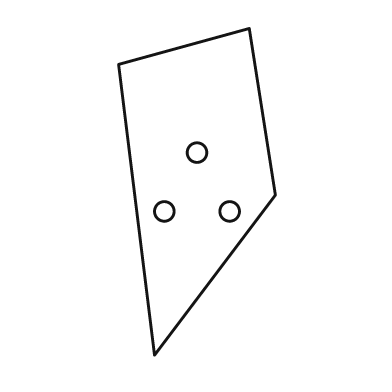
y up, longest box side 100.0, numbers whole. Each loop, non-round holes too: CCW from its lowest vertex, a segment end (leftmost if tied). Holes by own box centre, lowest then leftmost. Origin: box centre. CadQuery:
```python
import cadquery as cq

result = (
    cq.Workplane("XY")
    .moveTo(-13.0, -50.0)
    .lineTo(24.0, -1.0)
    .lineTo(16.0, 50.0)
    .lineTo(-24.0, 39.0)
    .close()
    .moveTo(-10.0, -6.0)
    .circle(3.0)
    .moveTo(10.0, -6.0)
    .circle(3.0)
    .moveTo(0.0, 12.0)
    .circle(3.0)
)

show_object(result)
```